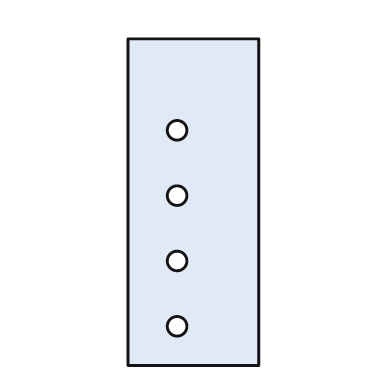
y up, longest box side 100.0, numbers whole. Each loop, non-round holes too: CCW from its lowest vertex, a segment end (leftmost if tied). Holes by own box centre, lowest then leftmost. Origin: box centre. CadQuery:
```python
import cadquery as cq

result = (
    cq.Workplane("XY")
    .moveTo(-20.0, -50.0)
    .lineTo(20.0, -50.0)
    .lineTo(20.0, 50.0)
    .lineTo(-20.0, 50.0)
    .close()
    .moveTo(-5.0, -38.0)
    .circle(3.0)
    .moveTo(-5.0, -18.0)
    .circle(3.0)
    .moveTo(-5.0, 2.0)
    .circle(3.0)
    .moveTo(-5.0, 22.0)
    .circle(3.0)
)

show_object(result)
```